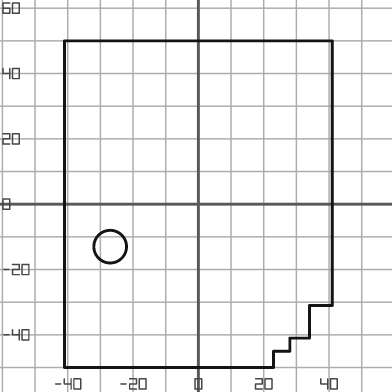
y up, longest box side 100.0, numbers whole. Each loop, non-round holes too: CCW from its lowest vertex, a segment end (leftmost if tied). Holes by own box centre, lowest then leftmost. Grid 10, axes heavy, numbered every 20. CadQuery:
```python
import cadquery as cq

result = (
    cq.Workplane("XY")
    .moveTo(-41.0, -50.0)
    .lineTo(23.0, -50.0)
    .lineTo(23.0, -45.0)
    .lineTo(28.0, -45.0)
    .lineTo(28.0, -41.0)
    .lineTo(34.0, -41.0)
    .lineTo(34.0, -31.0)
    .lineTo(41.0, -31.0)
    .lineTo(41.0, 50.0)
    .lineTo(-41.0, 50.0)
    .close()
    .moveTo(-27.0, -13.0)
    .circle(5.0)
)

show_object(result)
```